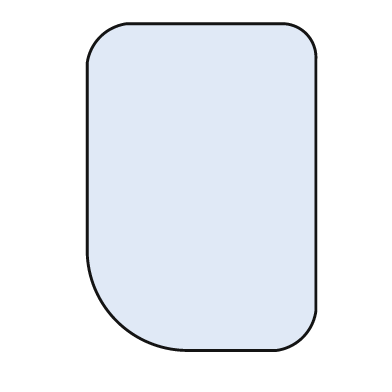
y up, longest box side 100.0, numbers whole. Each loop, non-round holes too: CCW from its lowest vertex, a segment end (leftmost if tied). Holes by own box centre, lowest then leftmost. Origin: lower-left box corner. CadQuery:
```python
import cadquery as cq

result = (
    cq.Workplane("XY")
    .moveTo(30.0, 0.0)
    .lineTo(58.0, 0.0)
    .threePointArc((66.0, 4.0), (70.0, 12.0))
    .lineTo(70.0, 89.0)
    .threePointArc((67.0, 97.0), (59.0, 100.0))
    .lineTo(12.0, 100.0)
    .threePointArc((4.0, 96.0), (0.0, 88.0))
    .lineTo(0.0, 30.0)
    .threePointArc((9.0, 9.0), (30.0, 0.0))
    .close()
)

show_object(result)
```